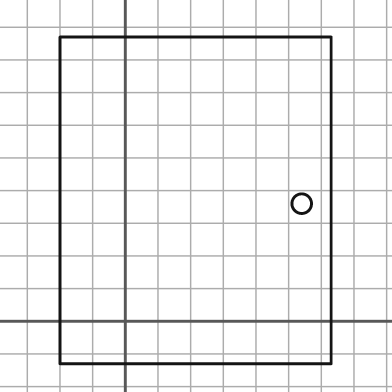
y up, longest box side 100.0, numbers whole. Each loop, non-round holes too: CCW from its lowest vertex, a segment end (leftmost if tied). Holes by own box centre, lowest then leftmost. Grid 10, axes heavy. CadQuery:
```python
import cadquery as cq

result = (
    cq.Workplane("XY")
    .moveTo(-20.0, -13.0)
    .lineTo(63.0, -13.0)
    .lineTo(63.0, 87.0)
    .lineTo(-20.0, 87.0)
    .close()
    .moveTo(54.0, 36.0)
    .circle(3.0)
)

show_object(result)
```